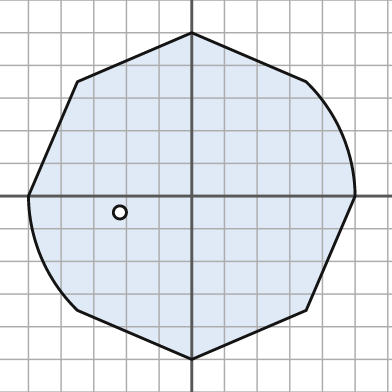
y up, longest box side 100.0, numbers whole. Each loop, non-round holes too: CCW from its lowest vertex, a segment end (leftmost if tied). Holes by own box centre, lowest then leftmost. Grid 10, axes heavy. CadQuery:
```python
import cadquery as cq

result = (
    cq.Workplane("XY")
    .moveTo(0.0, -50.0)
    .lineTo(35.0, -35.0)
    .lineTo(50.0, 0.0)
    .threePointArc((46.0, 19.0), (35.0, 35.0))
    .lineTo(0.0, 50.0)
    .lineTo(-35.0, 35.0)
    .lineTo(-50.0, 0.0)
    .threePointArc((-46.0, -19.0), (-35.0, -35.0))
    .close()
    .moveTo(-22.0, -5.0)
    .circle(2.0)
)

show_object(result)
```